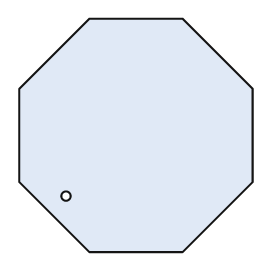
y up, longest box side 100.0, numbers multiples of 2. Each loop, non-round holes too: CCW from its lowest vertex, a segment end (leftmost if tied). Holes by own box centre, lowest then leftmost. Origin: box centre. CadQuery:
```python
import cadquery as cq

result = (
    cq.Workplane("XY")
    .moveTo(-20.0, -50.0)
    .lineTo(20.0, -50.0)
    .lineTo(50.0, -20.0)
    .lineTo(50.0, 20.0)
    .lineTo(20.0, 50.0)
    .lineTo(-20.0, 50.0)
    .lineTo(-50.0, 20.0)
    .lineTo(-50.0, -20.0)
    .close()
    .moveTo(-30.0, -26.0)
    .circle(2.0)
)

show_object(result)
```